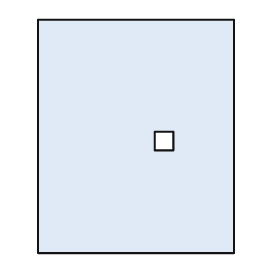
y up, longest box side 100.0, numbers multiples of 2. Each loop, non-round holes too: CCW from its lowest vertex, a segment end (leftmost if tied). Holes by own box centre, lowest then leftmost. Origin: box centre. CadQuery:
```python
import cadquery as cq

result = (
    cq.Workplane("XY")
    .moveTo(-42.0, -50.0)
    .lineTo(42.0, -50.0)
    .lineTo(42.0, 50.0)
    .lineTo(-42.0, 50.0)
    .close()
    .moveTo(8.0, -6.0)
    .lineTo(16.0, -6.0)
    .lineTo(16.0, 2.0)
    .lineTo(8.0, 2.0)
    .close()
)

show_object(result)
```